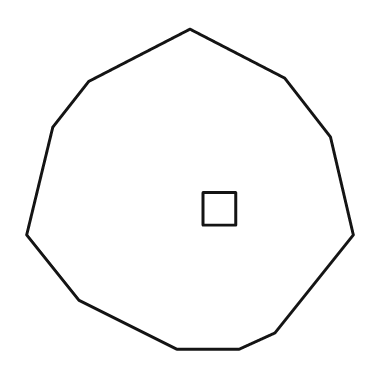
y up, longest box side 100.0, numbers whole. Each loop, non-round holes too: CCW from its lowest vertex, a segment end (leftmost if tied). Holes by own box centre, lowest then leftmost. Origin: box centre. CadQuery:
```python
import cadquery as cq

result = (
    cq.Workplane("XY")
    .moveTo(-4.0, -49.0)
    .lineTo(15.0, -49.0)
    .lineTo(26.0, -44.0)
    .lineTo(50.0, -14.0)
    .lineTo(43.0, 16.0)
    .lineTo(29.0, 34.0)
    .lineTo(0.0, 49.0)
    .lineTo(-31.0, 33.0)
    .lineTo(-42.0, 19.0)
    .lineTo(-50.0, -14.0)
    .lineTo(-34.0, -34.0)
    .close()
    .moveTo(4.0, -11.0)
    .lineTo(14.0, -11.0)
    .lineTo(14.0, -1.0)
    .lineTo(4.0, -1.0)
    .close()
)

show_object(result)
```